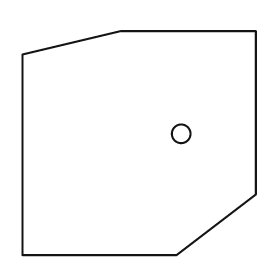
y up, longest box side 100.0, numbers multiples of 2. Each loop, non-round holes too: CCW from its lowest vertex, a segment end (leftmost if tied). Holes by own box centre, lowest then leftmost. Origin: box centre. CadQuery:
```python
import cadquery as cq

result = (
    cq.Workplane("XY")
    .moveTo(-50.0, -48.0)
    .lineTo(16.0, -48.0)
    .lineTo(50.0, -22.0)
    .lineTo(50.0, 48.0)
    .lineTo(-8.0, 48.0)
    .lineTo(-50.0, 38.0)
    .close()
    .moveTo(18.0, 4.0)
    .circle(4.0)
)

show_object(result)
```